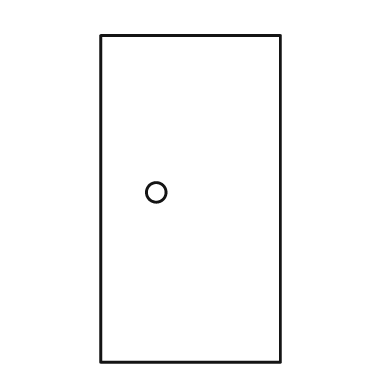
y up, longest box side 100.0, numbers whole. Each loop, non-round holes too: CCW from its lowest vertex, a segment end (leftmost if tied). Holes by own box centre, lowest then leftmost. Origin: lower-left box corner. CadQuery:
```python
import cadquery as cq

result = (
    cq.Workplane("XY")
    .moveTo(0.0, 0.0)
    .lineTo(55.0, 0.0)
    .lineTo(55.0, 100.0)
    .lineTo(0.0, 100.0)
    .close()
    .moveTo(17.0, 52.0)
    .circle(3.0)
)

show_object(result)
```